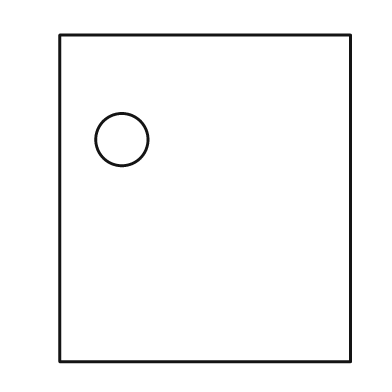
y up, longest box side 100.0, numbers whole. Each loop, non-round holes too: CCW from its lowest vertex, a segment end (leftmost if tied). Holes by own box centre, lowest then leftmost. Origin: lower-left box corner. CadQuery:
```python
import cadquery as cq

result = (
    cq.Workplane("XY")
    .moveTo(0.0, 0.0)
    .lineTo(89.0, 0.0)
    .lineTo(89.0, 100.0)
    .lineTo(0.0, 100.0)
    .close()
    .moveTo(19.0, 68.0)
    .circle(8.0)
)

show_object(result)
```